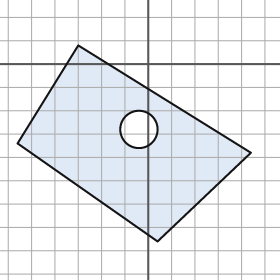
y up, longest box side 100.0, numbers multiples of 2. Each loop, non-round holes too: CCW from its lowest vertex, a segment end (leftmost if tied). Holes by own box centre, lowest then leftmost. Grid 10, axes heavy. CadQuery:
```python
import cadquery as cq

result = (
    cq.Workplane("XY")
    .moveTo(4.0, -76.0)
    .lineTo(44.0, -38.0)
    .lineTo(-30.0, 8.0)
    .lineTo(-56.0, -34.0)
    .close()
    .moveTo(-4.0, -28.0)
    .circle(8.0)
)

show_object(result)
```